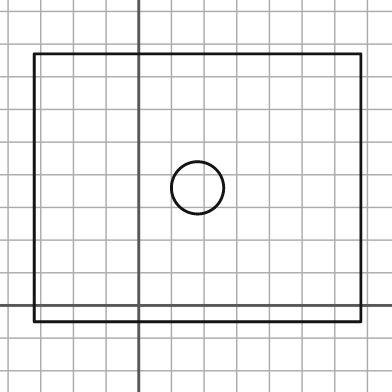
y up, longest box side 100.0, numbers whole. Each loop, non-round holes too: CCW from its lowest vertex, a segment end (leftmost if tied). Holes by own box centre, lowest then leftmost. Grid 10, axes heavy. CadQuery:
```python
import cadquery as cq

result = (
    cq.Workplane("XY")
    .moveTo(-32.0, -5.0)
    .lineTo(68.0, -5.0)
    .lineTo(68.0, 77.0)
    .lineTo(-32.0, 77.0)
    .close()
    .moveTo(18.0, 36.0)
    .circle(8.0)
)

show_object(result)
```